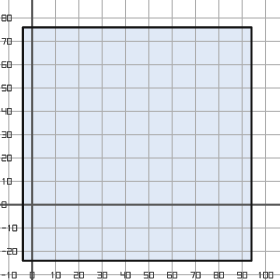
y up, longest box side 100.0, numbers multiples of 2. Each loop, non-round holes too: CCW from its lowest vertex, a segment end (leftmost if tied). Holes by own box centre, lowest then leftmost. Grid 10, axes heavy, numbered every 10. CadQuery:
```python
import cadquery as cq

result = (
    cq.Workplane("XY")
    .moveTo(-4.0, -24.0)
    .lineTo(94.0, -24.0)
    .lineTo(94.0, 76.0)
    .lineTo(-4.0, 76.0)
    .close()
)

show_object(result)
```